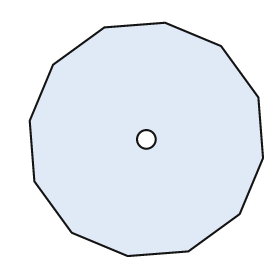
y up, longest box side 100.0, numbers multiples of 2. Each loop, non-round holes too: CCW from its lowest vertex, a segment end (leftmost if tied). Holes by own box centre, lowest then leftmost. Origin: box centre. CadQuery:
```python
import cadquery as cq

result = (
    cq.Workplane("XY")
    .moveTo(-8.0, -50.0)
    .lineTo(18.0, -48.0)
    .lineTo(40.0, -32.0)
    .lineTo(50.0, -8.0)
    .lineTo(48.0, 18.0)
    .lineTo(32.0, 40.0)
    .lineTo(8.0, 50.0)
    .lineTo(-18.0, 48.0)
    .lineTo(-40.0, 32.0)
    .lineTo(-50.0, 8.0)
    .lineTo(-48.0, -18.0)
    .lineTo(-32.0, -40.0)
    .close()
    .moveTo(0.0, 0.0)
    .circle(4.0)
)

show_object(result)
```